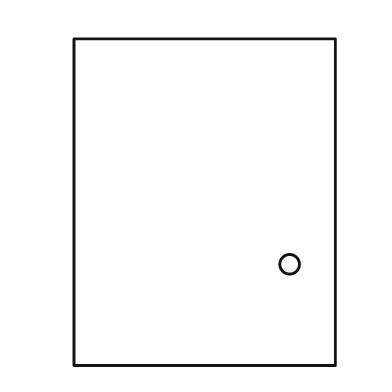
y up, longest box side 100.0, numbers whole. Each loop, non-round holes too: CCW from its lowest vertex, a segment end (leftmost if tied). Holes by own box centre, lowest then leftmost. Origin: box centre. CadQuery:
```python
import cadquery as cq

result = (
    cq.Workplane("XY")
    .moveTo(-40.0, -50.0)
    .lineTo(40.0, -50.0)
    .lineTo(40.0, 50.0)
    .lineTo(-40.0, 50.0)
    .close()
    .moveTo(26.0, -19.0)
    .circle(3.0)
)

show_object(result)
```